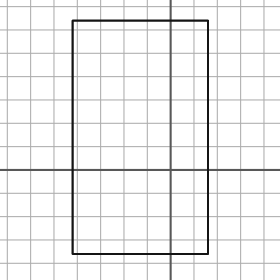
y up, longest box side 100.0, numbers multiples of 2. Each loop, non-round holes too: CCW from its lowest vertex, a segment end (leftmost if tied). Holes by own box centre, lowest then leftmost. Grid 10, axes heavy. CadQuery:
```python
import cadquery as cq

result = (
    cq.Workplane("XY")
    .moveTo(-42.0, -36.0)
    .lineTo(16.0, -36.0)
    .lineTo(16.0, 64.0)
    .lineTo(-42.0, 64.0)
    .close()
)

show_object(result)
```